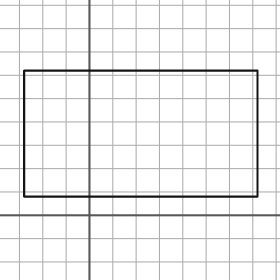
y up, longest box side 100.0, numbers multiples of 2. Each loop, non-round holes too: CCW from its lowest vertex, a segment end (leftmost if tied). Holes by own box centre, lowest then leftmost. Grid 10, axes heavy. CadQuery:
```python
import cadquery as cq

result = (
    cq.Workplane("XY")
    .moveTo(-28.0, 8.0)
    .lineTo(72.0, 8.0)
    .lineTo(72.0, 62.0)
    .lineTo(-28.0, 62.0)
    .close()
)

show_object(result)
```